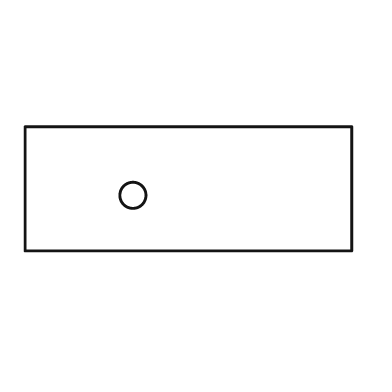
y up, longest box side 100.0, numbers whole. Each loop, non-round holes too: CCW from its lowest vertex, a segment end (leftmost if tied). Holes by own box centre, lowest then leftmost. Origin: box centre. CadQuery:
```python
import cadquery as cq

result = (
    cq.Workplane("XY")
    .moveTo(-50.0, -19.0)
    .lineTo(50.0, -19.0)
    .lineTo(50.0, 19.0)
    .lineTo(-50.0, 19.0)
    .close()
    .moveTo(-17.0, -2.0)
    .circle(4.0)
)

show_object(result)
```